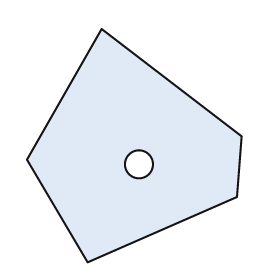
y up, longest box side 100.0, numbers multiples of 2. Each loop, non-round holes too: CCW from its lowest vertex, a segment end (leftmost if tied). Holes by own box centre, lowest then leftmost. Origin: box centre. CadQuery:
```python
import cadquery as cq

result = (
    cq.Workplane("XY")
    .moveTo(-20.0, -50.0)
    .lineTo(44.0, -22.0)
    .lineTo(46.0, 4.0)
    .lineTo(-14.0, 50.0)
    .lineTo(-46.0, -6.0)
    .close()
    .moveTo(2.0, -8.0)
    .circle(6.0)
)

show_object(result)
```